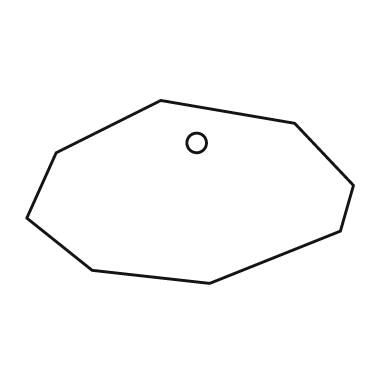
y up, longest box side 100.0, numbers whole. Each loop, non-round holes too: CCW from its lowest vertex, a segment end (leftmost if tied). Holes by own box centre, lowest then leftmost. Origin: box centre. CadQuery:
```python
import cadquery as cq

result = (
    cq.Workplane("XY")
    .moveTo(6.0, -28.0)
    .lineTo(46.0, -12.0)
    .lineTo(50.0, 2.0)
    .lineTo(32.0, 21.0)
    .lineTo(-9.0, 28.0)
    .lineTo(-41.0, 12.0)
    .lineTo(-50.0, -8.0)
    .lineTo(-30.0, -24.0)
    .close()
    .moveTo(2.0, 15.0)
    .circle(3.0)
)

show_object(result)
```